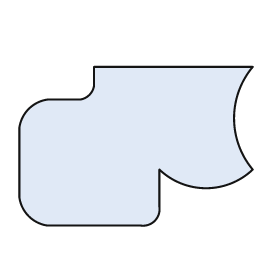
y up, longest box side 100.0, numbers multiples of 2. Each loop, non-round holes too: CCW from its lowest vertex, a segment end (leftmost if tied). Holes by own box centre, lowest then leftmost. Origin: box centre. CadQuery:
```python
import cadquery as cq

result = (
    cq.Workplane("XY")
    .moveTo(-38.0, -34.0)
    .lineTo(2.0, -34.0)
    .threePointArc((8.0, -32.0), (10.0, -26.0))
    .lineTo(10.0, -10.0)
    .threePointArc((30.0, -18.0), (50.0, -10.0))
    .threePointArc((42.0, 12.0), (50.0, 34.0))
    .lineTo(-18.0, 34.0)
    .lineTo(-18.0, 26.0)
    .threePointArc((-20.0, 22.0), (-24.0, 20.0))
    .lineTo(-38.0, 20.0)
    .threePointArc((-46.0, 16.0), (-50.0, 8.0))
    .lineTo(-50.0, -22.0)
    .threePointArc((-46.0, -30.0), (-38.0, -34.0))
    .close()
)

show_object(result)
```